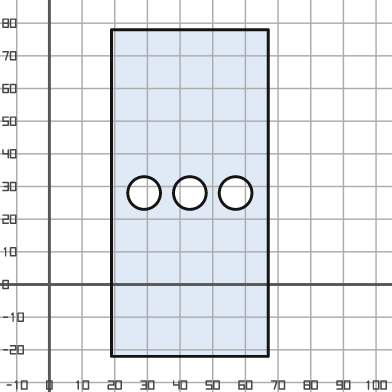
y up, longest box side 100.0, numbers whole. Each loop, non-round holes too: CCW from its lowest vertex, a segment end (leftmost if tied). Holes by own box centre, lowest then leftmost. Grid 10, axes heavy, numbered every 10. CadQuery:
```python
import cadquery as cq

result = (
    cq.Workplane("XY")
    .moveTo(19.0, -22.0)
    .lineTo(67.0, -22.0)
    .lineTo(67.0, 78.0)
    .lineTo(19.0, 78.0)
    .close()
    .moveTo(29.0, 28.0)
    .circle(5.0)
    .moveTo(43.0, 28.0)
    .circle(5.0)
    .moveTo(57.0, 28.0)
    .circle(5.0)
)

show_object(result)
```